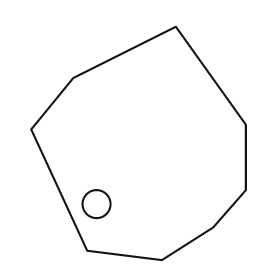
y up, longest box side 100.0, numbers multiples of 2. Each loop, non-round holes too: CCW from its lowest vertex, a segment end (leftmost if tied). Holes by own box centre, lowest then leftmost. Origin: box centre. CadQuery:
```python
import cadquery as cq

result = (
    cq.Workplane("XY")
    .moveTo(10.0, -50.0)
    .lineTo(32.0, -36.0)
    .lineTo(46.0, -20.0)
    .lineTo(46.0, 8.0)
    .lineTo(16.0, 50.0)
    .lineTo(-28.0, 28.0)
    .lineTo(-46.0, 6.0)
    .lineTo(-22.0, -46.0)
    .close()
    .moveTo(-18.0, -26.0)
    .circle(6.0)
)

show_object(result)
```